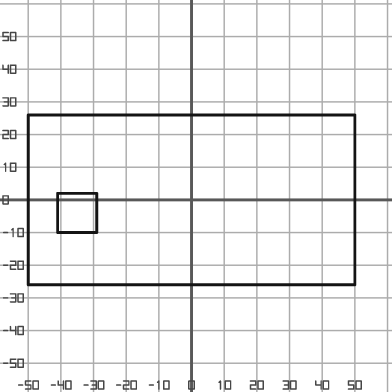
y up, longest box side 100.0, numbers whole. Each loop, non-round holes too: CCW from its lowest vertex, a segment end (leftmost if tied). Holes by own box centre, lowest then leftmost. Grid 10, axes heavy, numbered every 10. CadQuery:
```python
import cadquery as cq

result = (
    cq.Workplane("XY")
    .moveTo(-50.0, -26.0)
    .lineTo(50.0, -26.0)
    .lineTo(50.0, 26.0)
    .lineTo(-50.0, 26.0)
    .close()
    .moveTo(-41.0, -10.0)
    .lineTo(-29.0, -10.0)
    .lineTo(-29.0, 2.0)
    .lineTo(-41.0, 2.0)
    .close()
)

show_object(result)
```